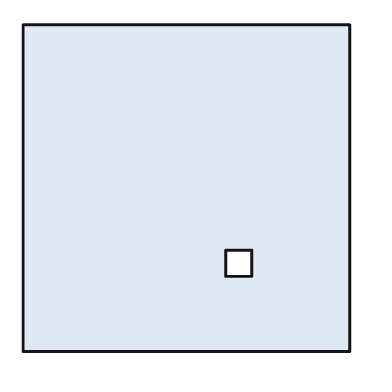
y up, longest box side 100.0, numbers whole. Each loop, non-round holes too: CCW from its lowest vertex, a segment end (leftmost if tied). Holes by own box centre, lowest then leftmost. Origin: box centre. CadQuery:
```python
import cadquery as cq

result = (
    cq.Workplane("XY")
    .moveTo(-50.0, -50.0)
    .lineTo(50.0, -50.0)
    .lineTo(50.0, 50.0)
    .lineTo(-50.0, 50.0)
    .close()
    .moveTo(12.0, -27.0)
    .lineTo(20.0, -27.0)
    .lineTo(20.0, -19.0)
    .lineTo(12.0, -19.0)
    .close()
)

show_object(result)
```